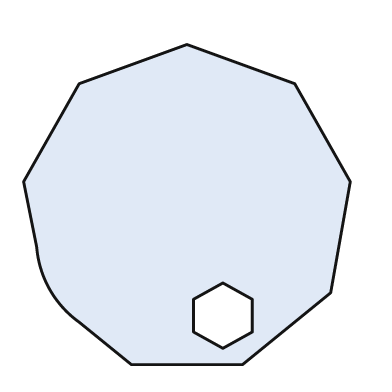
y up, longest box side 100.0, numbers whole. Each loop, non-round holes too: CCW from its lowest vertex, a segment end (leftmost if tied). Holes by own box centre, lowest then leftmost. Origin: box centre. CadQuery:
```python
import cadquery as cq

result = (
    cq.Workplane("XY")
    .moveTo(-17.0, -49.0)
    .lineTo(17.0, -49.0)
    .lineTo(44.0, -27.0)
    .lineTo(50.0, 7.0)
    .lineTo(33.0, 37.0)
    .lineTo(0.0, 49.0)
    .lineTo(-33.0, 37.0)
    .lineTo(-50.0, 7.0)
    .lineTo(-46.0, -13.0)
    .threePointArc((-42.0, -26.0), (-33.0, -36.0))
    .close()
    .moveTo(11.0, -44.0)
    .lineTo(20.0, -39.0)
    .lineTo(20.0, -29.0)
    .lineTo(11.0, -24.0)
    .lineTo(2.0, -29.0)
    .lineTo(2.0, -39.0)
    .close()
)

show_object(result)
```